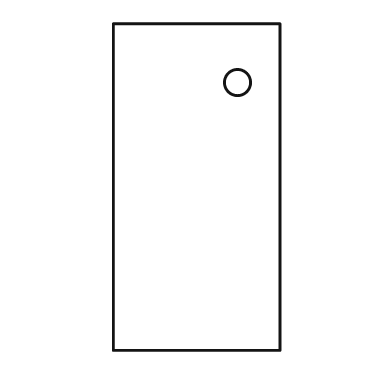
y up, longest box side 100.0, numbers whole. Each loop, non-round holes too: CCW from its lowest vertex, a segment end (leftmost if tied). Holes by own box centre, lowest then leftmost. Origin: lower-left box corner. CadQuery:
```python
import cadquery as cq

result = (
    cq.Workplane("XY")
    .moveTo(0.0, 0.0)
    .lineTo(51.0, 0.0)
    .lineTo(51.0, 100.0)
    .lineTo(0.0, 100.0)
    .close()
    .moveTo(38.0, 82.0)
    .circle(4.0)
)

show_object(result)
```